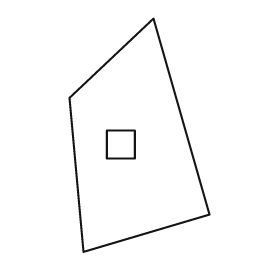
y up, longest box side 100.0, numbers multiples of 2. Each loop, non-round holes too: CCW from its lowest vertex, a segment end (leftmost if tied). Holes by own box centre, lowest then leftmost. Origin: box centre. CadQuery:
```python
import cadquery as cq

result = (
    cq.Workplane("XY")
    .moveTo(-24.0, -50.0)
    .lineTo(30.0, -34.0)
    .lineTo(6.0, 50.0)
    .lineTo(-30.0, 16.0)
    .close()
    .moveTo(-14.0, -10.0)
    .lineTo(-2.0, -10.0)
    .lineTo(-2.0, 2.0)
    .lineTo(-14.0, 2.0)
    .close()
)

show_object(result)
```